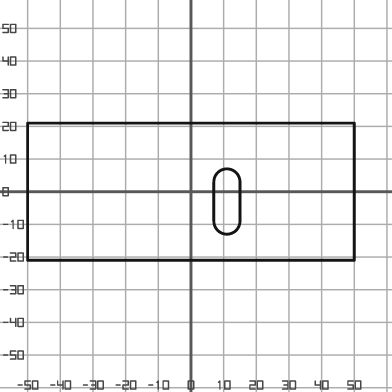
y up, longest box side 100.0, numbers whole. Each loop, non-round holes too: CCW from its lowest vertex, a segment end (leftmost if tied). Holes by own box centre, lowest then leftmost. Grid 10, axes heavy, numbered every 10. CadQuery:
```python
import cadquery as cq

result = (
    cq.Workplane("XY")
    .moveTo(-50.0, -21.0)
    .lineTo(50.0, -21.0)
    .lineTo(50.0, 21.0)
    .lineTo(-50.0, 21.0)
    .close()
    .moveTo(7.0, -9.0)
    .threePointArc((11.0, -13.0), (15.0, -9.0))
    .lineTo(15.0, 3.0)
    .threePointArc((11.0, 7.0), (7.0, 3.0))
    .close()
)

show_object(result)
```